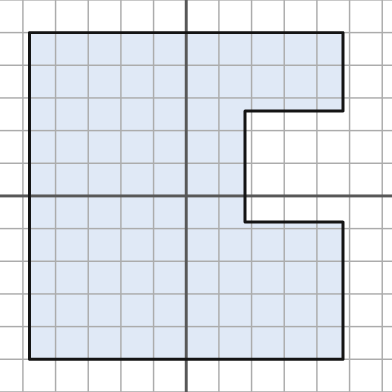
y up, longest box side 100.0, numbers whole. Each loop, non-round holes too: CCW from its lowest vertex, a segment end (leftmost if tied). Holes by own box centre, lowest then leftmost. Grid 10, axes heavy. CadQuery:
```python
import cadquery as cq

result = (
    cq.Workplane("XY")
    .moveTo(-48.0, -50.0)
    .lineTo(48.0, -50.0)
    .lineTo(48.0, -8.0)
    .lineTo(18.0, -8.0)
    .lineTo(18.0, 26.0)
    .lineTo(48.0, 26.0)
    .lineTo(48.0, 50.0)
    .lineTo(-48.0, 50.0)
    .close()
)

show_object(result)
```